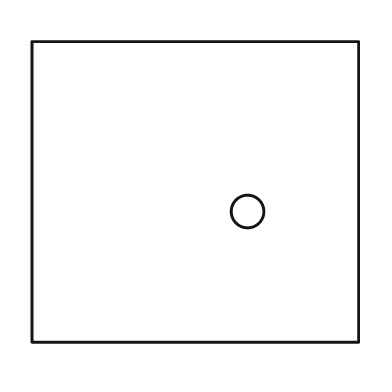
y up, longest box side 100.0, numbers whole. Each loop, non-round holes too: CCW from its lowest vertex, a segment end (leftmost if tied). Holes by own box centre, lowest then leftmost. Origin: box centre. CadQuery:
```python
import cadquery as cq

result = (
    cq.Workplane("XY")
    .moveTo(-50.0, -46.0)
    .lineTo(50.0, -46.0)
    .lineTo(50.0, 46.0)
    .lineTo(-50.0, 46.0)
    .close()
    .moveTo(16.0, -6.0)
    .circle(5.0)
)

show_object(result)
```